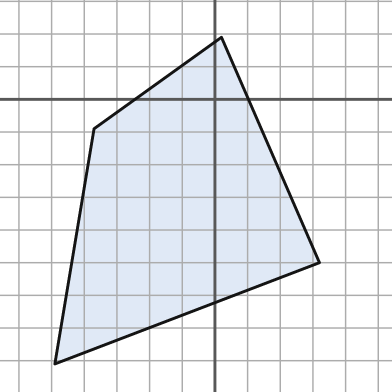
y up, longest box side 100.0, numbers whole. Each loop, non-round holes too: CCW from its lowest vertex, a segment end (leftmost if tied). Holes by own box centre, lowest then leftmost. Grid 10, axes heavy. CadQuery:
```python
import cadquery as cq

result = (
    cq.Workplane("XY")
    .moveTo(-49.0, -81.0)
    .lineTo(32.0, -50.0)
    .lineTo(2.0, 19.0)
    .lineTo(-37.0, -9.0)
    .close()
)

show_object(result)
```